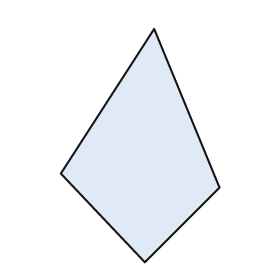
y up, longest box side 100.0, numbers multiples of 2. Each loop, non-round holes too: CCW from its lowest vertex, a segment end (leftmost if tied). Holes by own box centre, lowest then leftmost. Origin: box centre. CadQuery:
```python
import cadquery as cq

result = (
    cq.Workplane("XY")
    .moveTo(2.0, -50.0)
    .lineTo(34.0, -18.0)
    .lineTo(6.0, 50.0)
    .lineTo(-34.0, -12.0)
    .close()
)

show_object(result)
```